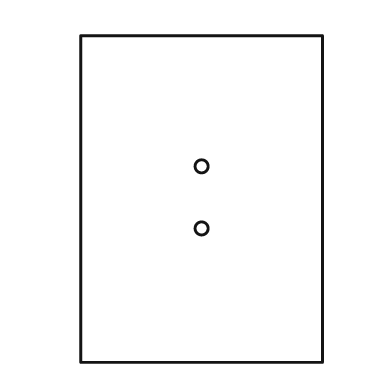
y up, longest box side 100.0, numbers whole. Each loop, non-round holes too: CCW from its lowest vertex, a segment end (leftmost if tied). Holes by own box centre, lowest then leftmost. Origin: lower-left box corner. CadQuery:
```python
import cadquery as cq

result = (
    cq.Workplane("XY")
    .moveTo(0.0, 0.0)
    .lineTo(74.0, 0.0)
    .lineTo(74.0, 100.0)
    .lineTo(0.0, 100.0)
    .close()
    .moveTo(37.0, 41.0)
    .circle(2.0)
    .moveTo(37.0, 60.0)
    .circle(2.0)
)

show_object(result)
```